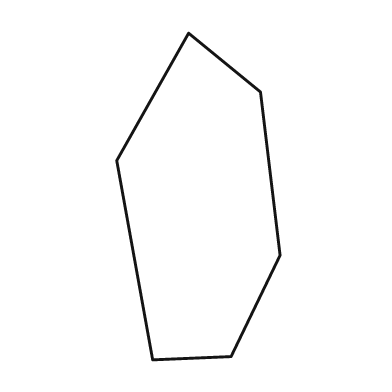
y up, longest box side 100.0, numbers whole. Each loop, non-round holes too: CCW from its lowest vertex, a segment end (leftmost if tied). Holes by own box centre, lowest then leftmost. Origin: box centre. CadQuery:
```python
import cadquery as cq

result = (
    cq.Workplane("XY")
    .moveTo(-14.0, -50.0)
    .lineTo(10.0, -49.0)
    .lineTo(25.0, -18.0)
    .lineTo(19.0, 32.0)
    .lineTo(-3.0, 50.0)
    .lineTo(-25.0, 11.0)
    .close()
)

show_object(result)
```